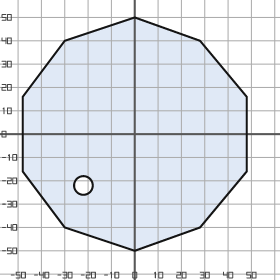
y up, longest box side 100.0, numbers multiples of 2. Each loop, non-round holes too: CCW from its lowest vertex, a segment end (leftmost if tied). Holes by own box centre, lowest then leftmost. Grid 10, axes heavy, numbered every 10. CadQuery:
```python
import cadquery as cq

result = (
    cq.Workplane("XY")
    .moveTo(0.0, -50.0)
    .lineTo(28.0, -40.0)
    .lineTo(48.0, -16.0)
    .lineTo(48.0, 16.0)
    .lineTo(28.0, 40.0)
    .lineTo(0.0, 50.0)
    .lineTo(-30.0, 40.0)
    .lineTo(-48.0, 16.0)
    .lineTo(-48.0, -16.0)
    .lineTo(-30.0, -40.0)
    .close()
    .moveTo(-22.0, -22.0)
    .circle(4.0)
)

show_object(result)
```